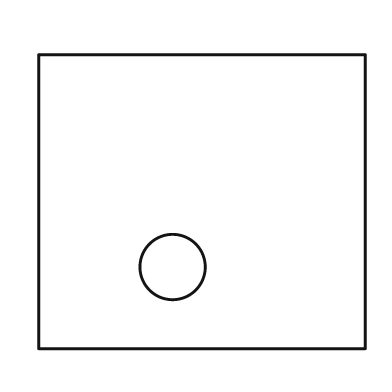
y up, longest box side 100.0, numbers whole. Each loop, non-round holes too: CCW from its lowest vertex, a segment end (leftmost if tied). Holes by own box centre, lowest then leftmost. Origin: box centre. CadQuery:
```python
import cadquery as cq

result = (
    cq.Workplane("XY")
    .moveTo(-50.0, -45.0)
    .lineTo(50.0, -45.0)
    .lineTo(50.0, 45.0)
    .lineTo(-50.0, 45.0)
    .close()
    .moveTo(-9.0, -20.0)
    .circle(10.0)
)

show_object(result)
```